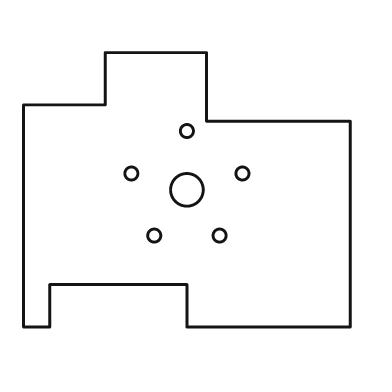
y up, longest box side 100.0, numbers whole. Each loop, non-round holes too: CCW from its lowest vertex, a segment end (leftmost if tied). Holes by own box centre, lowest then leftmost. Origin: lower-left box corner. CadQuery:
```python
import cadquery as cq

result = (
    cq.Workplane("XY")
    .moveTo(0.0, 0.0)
    .lineTo(8.0, 0.0)
    .lineTo(8.0, 13.0)
    .lineTo(50.0, 13.0)
    .lineTo(50.0, 0.0)
    .lineTo(100.0, 0.0)
    .lineTo(100.0, 63.0)
    .lineTo(56.0, 63.0)
    .lineTo(56.0, 84.0)
    .lineTo(25.0, 84.0)
    .lineTo(25.0, 68.0)
    .lineTo(0.0, 68.0)
    .close()
    .moveTo(40.0, 28.0)
    .circle(2.0)
    .moveTo(60.0, 28.0)
    .circle(2.0)
    .moveTo(50.0, 42.0)
    .circle(5.0)
    .moveTo(33.0, 47.0)
    .circle(2.0)
    .moveTo(67.0, 47.0)
    .circle(2.0)
    .moveTo(50.0, 60.0)
    .circle(2.0)
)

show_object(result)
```